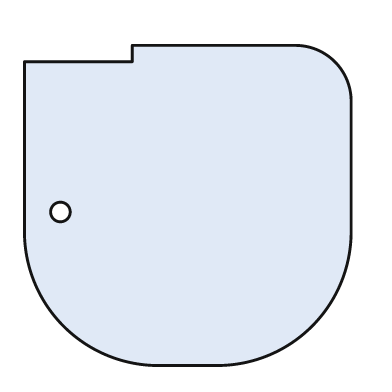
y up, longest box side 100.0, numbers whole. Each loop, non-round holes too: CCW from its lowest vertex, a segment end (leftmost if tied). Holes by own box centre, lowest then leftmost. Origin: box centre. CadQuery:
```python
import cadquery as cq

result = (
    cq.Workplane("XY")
    .moveTo(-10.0, -49.0)
    .lineTo(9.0, -49.0)
    .threePointArc((38.0, -37.0), (50.0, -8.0))
    .lineTo(50.0, 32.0)
    .threePointArc((45.0, 44.0), (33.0, 49.0))
    .lineTo(-17.0, 49.0)
    .lineTo(-17.0, 44.0)
    .lineTo(-50.0, 44.0)
    .lineTo(-50.0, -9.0)
    .threePointArc((-38.0, -37.0), (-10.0, -49.0))
    .close()
    .moveTo(-39.0, -2.0)
    .circle(3.0)
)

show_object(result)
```